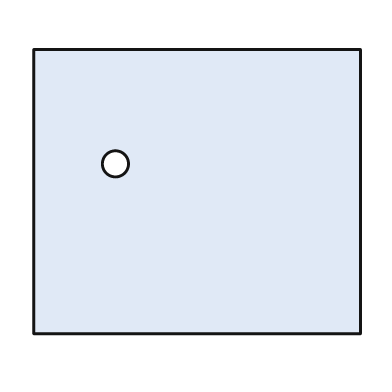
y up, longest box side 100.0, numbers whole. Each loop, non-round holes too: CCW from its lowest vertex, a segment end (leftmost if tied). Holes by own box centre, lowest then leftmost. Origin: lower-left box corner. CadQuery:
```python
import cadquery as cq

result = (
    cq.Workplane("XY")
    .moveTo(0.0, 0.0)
    .lineTo(100.0, 0.0)
    .lineTo(100.0, 87.0)
    .lineTo(0.0, 87.0)
    .close()
    .moveTo(25.0, 52.0)
    .circle(4.0)
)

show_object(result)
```